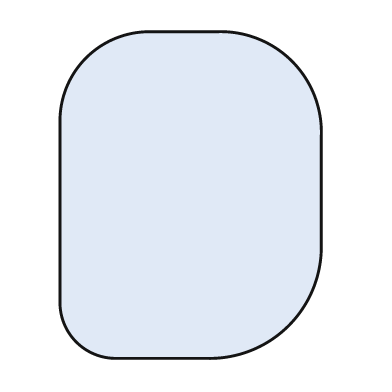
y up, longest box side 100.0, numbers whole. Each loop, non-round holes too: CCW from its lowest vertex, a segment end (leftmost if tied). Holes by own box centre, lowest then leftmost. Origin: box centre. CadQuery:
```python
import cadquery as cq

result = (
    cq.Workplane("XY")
    .moveTo(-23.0, -50.0)
    .lineTo(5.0, -50.0)
    .threePointArc((30.0, -40.0), (40.0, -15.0))
    .lineTo(40.0, 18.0)
    .threePointArc((31.0, 41.0), (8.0, 50.0))
    .lineTo(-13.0, 50.0)
    .threePointArc((-32.0, 42.0), (-40.0, 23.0))
    .lineTo(-40.0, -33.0)
    .threePointArc((-35.0, -45.0), (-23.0, -50.0))
    .close()
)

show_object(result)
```